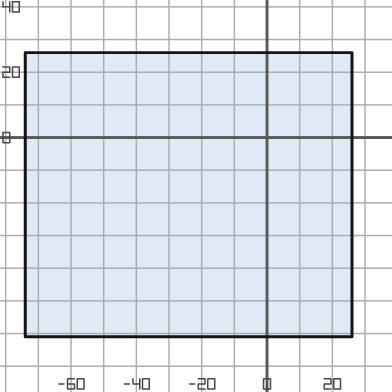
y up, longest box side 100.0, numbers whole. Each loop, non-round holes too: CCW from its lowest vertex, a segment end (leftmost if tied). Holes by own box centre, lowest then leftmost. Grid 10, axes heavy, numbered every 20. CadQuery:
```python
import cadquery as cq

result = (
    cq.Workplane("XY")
    .moveTo(-74.0, -61.0)
    .lineTo(26.0, -61.0)
    .lineTo(26.0, 26.0)
    .lineTo(-74.0, 26.0)
    .close()
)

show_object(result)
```